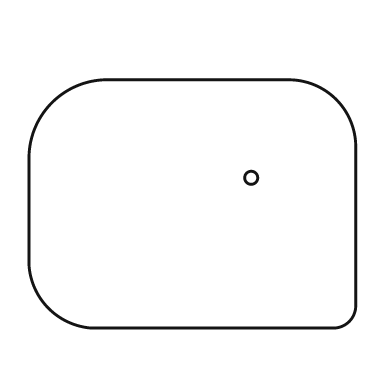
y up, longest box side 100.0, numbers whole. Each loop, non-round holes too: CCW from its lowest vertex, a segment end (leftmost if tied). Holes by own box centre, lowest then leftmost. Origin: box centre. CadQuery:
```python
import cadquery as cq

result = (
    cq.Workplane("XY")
    .moveTo(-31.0, -38.0)
    .lineTo(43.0, -38.0)
    .threePointArc((48.0, -36.0), (50.0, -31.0))
    .lineTo(50.0, 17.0)
    .threePointArc((44.0, 32.0), (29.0, 38.0))
    .lineTo(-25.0, 38.0)
    .threePointArc((-43.0, 31.0), (-50.0, 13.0))
    .lineTo(-50.0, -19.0)
    .threePointArc((-44.0, -32.0), (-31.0, -38.0))
    .close()
    .moveTo(18.0, 8.0)
    .circle(2.0)
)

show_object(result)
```